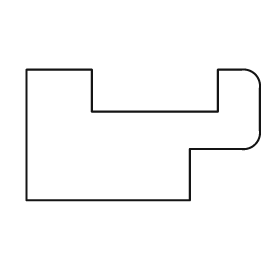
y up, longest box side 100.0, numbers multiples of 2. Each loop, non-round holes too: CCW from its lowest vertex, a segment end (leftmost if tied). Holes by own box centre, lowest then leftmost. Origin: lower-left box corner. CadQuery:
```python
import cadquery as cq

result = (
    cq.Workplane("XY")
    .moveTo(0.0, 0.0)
    .lineTo(70.0, 0.0)
    .lineTo(70.0, 22.0)
    .lineTo(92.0, 22.0)
    .threePointArc((98.0, 24.0), (100.0, 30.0))
    .lineTo(100.0, 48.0)
    .threePointArc((98.0, 54.0), (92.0, 56.0))
    .lineTo(82.0, 56.0)
    .lineTo(82.0, 38.0)
    .lineTo(28.0, 38.0)
    .lineTo(28.0, 56.0)
    .lineTo(0.0, 56.0)
    .close()
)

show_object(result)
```